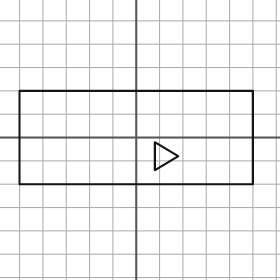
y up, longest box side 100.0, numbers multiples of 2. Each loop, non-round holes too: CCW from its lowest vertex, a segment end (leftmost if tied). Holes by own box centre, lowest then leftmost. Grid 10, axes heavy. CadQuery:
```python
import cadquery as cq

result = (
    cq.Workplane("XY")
    .moveTo(-50.0, -20.0)
    .lineTo(50.0, -20.0)
    .lineTo(50.0, 20.0)
    .lineTo(-50.0, 20.0)
    .close()
    .moveTo(8.0, -14.0)
    .lineTo(18.0, -8.0)
    .lineTo(8.0, -2.0)
    .close()
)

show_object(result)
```